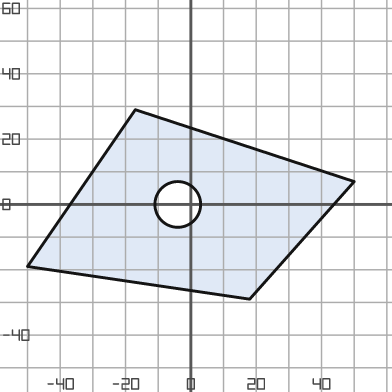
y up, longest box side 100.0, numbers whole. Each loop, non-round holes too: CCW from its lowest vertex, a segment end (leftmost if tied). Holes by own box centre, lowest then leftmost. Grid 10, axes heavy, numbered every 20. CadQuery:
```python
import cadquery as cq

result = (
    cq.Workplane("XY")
    .moveTo(18.0, -29.0)
    .lineTo(50.0, 7.0)
    .lineTo(-17.0, 29.0)
    .lineTo(-50.0, -19.0)
    .close()
    .moveTo(-4.0, 0.0)
    .circle(7.0)
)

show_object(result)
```